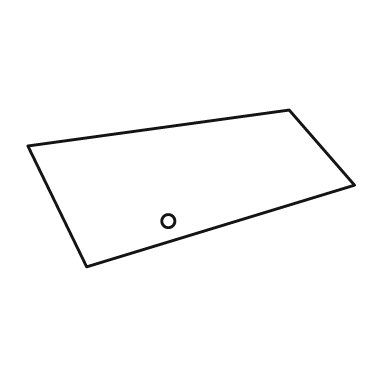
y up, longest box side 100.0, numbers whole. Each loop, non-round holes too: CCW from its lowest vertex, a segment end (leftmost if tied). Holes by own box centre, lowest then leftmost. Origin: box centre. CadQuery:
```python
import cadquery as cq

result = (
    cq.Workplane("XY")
    .moveTo(-32.0, -24.0)
    .lineTo(50.0, 1.0)
    .lineTo(30.0, 24.0)
    .lineTo(-50.0, 13.0)
    .close()
    .moveTo(-7.0, -10.0)
    .circle(2.0)
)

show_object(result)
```